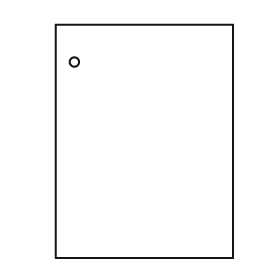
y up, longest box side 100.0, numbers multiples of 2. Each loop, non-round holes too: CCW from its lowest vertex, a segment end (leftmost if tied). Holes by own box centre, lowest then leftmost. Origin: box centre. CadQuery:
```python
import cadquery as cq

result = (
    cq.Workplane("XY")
    .moveTo(-38.0, -50.0)
    .lineTo(38.0, -50.0)
    .lineTo(38.0, 50.0)
    .lineTo(-38.0, 50.0)
    .close()
    .moveTo(-30.0, 34.0)
    .circle(2.0)
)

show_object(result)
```